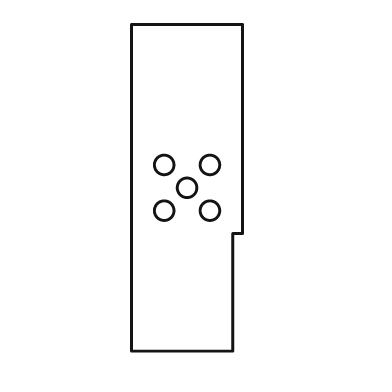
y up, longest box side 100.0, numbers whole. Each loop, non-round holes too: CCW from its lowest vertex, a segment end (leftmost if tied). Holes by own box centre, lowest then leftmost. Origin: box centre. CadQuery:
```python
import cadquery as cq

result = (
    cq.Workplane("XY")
    .moveTo(-17.0, -50.0)
    .lineTo(14.0, -50.0)
    .lineTo(14.0, -14.0)
    .lineTo(17.0, -14.0)
    .lineTo(17.0, 50.0)
    .lineTo(-17.0, 50.0)
    .close()
    .moveTo(-7.0, -7.0)
    .circle(3.0)
    .moveTo(7.0, -7.0)
    .circle(3.0)
    .moveTo(0.0, 0.0)
    .circle(3.0)
    .moveTo(-7.0, 7.0)
    .circle(3.0)
    .moveTo(7.0, 7.0)
    .circle(3.0)
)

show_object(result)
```